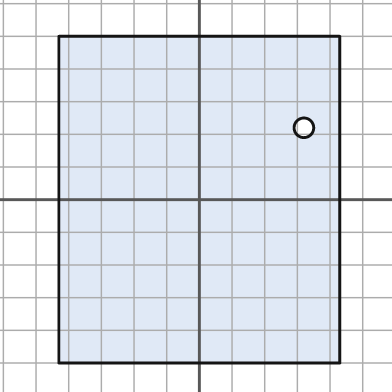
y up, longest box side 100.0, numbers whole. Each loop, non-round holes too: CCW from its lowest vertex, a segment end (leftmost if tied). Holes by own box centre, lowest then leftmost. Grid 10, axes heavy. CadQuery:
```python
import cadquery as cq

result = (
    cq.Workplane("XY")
    .moveTo(-43.0, -50.0)
    .lineTo(43.0, -50.0)
    .lineTo(43.0, 50.0)
    .lineTo(-43.0, 50.0)
    .close()
    .moveTo(32.0, 22.0)
    .circle(3.0)
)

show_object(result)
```